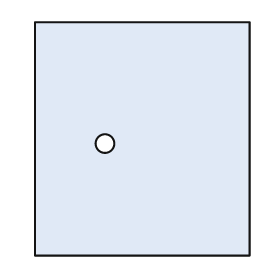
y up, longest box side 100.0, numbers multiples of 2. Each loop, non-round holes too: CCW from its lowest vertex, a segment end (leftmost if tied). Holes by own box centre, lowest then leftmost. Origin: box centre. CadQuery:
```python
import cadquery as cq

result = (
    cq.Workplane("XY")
    .moveTo(-46.0, -50.0)
    .lineTo(46.0, -50.0)
    .lineTo(46.0, 50.0)
    .lineTo(-46.0, 50.0)
    .close()
    .moveTo(-16.0, -2.0)
    .circle(4.0)
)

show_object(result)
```